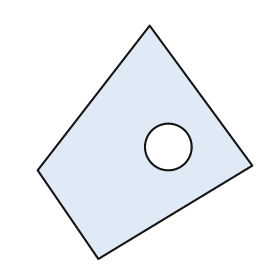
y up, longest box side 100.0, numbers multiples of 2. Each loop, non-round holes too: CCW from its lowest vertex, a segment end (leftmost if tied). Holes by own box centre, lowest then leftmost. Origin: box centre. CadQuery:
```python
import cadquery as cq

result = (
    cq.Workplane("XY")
    .moveTo(-20.0, -50.0)
    .lineTo(46.0, -10.0)
    .lineTo(2.0, 50.0)
    .lineTo(-46.0, -12.0)
    .close()
    .moveTo(10.0, -2.0)
    .circle(10.0)
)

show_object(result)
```